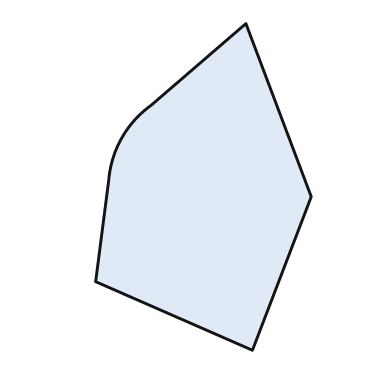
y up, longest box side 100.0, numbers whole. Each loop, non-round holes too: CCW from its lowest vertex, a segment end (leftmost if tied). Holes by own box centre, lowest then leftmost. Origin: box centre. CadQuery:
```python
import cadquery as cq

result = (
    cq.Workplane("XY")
    .moveTo(15.0, -50.0)
    .lineTo(33.0, -3.0)
    .lineTo(13.0, 50.0)
    .lineTo(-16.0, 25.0)
    .threePointArc((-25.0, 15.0), (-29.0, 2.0))
    .lineTo(-33.0, -29.0)
    .close()
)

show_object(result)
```